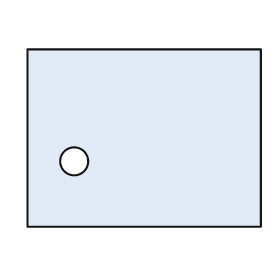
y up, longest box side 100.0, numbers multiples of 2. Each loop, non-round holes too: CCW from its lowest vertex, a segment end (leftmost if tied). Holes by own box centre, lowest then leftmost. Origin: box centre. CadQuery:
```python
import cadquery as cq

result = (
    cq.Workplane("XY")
    .moveTo(-50.0, -38.0)
    .lineTo(50.0, -38.0)
    .lineTo(50.0, 38.0)
    .lineTo(-50.0, 38.0)
    .close()
    .moveTo(-30.0, -10.0)
    .circle(6.0)
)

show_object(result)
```